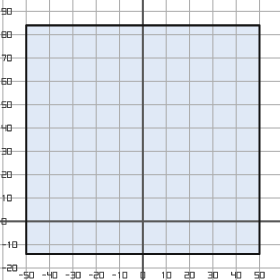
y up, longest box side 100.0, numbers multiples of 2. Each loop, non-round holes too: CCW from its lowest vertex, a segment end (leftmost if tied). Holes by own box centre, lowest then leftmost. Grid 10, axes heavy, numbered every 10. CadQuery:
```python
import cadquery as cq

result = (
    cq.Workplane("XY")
    .moveTo(-50.0, -14.0)
    .lineTo(50.0, -14.0)
    .lineTo(50.0, 84.0)
    .lineTo(-50.0, 84.0)
    .close()
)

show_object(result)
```